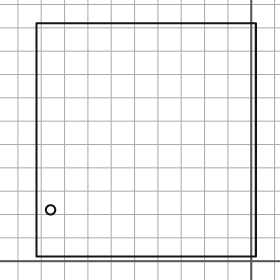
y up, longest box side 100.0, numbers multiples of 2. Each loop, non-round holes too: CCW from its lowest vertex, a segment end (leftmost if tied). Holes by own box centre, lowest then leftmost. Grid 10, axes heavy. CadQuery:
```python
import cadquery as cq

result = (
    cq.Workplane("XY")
    .moveTo(-92.0, 2.0)
    .lineTo(2.0, 2.0)
    .lineTo(2.0, 102.0)
    .lineTo(-92.0, 102.0)
    .close()
    .moveTo(-86.0, 22.0)
    .circle(2.0)
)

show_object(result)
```